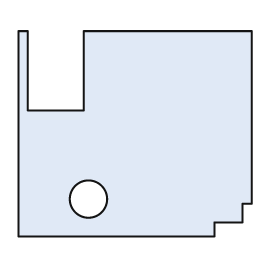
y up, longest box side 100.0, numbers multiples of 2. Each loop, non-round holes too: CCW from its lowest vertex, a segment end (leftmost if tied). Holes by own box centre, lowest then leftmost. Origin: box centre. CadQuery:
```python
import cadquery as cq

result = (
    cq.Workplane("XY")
    .moveTo(-50.0, -44.0)
    .lineTo(34.0, -44.0)
    .lineTo(34.0, -38.0)
    .lineTo(46.0, -38.0)
    .lineTo(46.0, -30.0)
    .lineTo(50.0, -30.0)
    .lineTo(50.0, 44.0)
    .lineTo(-22.0, 44.0)
    .lineTo(-22.0, 10.0)
    .lineTo(-46.0, 10.0)
    .lineTo(-46.0, 44.0)
    .lineTo(-50.0, 44.0)
    .close()
    .moveTo(-20.0, -28.0)
    .circle(8.0)
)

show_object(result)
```